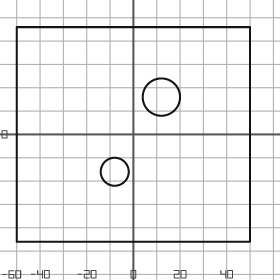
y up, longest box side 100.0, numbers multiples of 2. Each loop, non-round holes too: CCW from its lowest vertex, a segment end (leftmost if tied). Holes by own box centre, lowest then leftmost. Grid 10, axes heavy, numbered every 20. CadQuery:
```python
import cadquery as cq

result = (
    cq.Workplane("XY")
    .moveTo(-50.0, -46.0)
    .lineTo(50.0, -46.0)
    .lineTo(50.0, 46.0)
    .lineTo(-50.0, 46.0)
    .close()
    .moveTo(-8.0, -16.0)
    .circle(6.0)
    .moveTo(12.0, 16.0)
    .circle(8.0)
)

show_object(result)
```